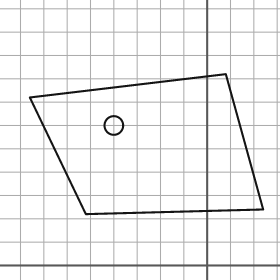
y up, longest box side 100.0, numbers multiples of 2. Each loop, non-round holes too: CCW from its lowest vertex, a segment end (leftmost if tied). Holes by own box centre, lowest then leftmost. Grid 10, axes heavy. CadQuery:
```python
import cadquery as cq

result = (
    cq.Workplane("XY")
    .moveTo(-52.0, 22.0)
    .lineTo(24.0, 24.0)
    .lineTo(8.0, 82.0)
    .lineTo(-76.0, 72.0)
    .close()
    .moveTo(-40.0, 60.0)
    .circle(4.0)
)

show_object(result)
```